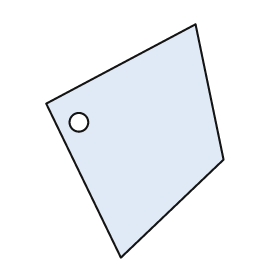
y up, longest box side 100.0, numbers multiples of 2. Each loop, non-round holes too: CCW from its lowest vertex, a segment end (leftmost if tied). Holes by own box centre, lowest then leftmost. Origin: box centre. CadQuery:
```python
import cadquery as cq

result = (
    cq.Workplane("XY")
    .moveTo(-6.0, -50.0)
    .lineTo(38.0, -8.0)
    .lineTo(26.0, 50.0)
    .lineTo(-38.0, 16.0)
    .close()
    .moveTo(-24.0, 8.0)
    .circle(4.0)
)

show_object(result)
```